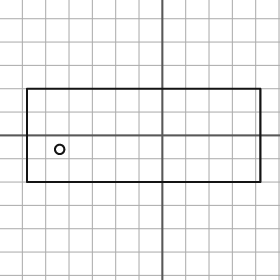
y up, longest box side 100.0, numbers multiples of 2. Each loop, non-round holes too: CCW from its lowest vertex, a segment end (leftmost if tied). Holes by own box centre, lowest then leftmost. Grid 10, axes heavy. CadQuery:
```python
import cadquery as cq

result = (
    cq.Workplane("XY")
    .moveTo(-58.0, -20.0)
    .lineTo(42.0, -20.0)
    .lineTo(42.0, 20.0)
    .lineTo(-58.0, 20.0)
    .close()
    .moveTo(-44.0, -6.0)
    .circle(2.0)
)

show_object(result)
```